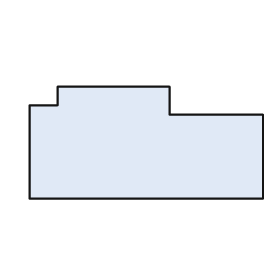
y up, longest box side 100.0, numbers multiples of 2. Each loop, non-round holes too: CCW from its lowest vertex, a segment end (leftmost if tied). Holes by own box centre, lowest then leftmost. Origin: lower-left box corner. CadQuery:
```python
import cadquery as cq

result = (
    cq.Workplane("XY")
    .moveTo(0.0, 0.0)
    .lineTo(100.0, 0.0)
    .lineTo(100.0, 36.0)
    .lineTo(60.0, 36.0)
    .lineTo(60.0, 48.0)
    .lineTo(12.0, 48.0)
    .lineTo(12.0, 40.0)
    .lineTo(0.0, 40.0)
    .close()
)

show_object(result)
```